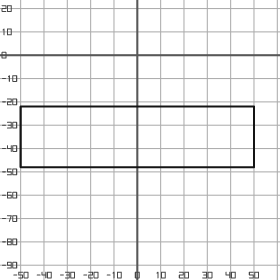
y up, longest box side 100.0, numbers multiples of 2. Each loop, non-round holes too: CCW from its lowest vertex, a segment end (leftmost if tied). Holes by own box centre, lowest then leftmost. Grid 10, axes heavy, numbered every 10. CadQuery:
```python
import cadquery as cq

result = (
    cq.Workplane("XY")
    .moveTo(-50.0, -48.0)
    .lineTo(50.0, -48.0)
    .lineTo(50.0, -22.0)
    .lineTo(-50.0, -22.0)
    .close()
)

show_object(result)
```